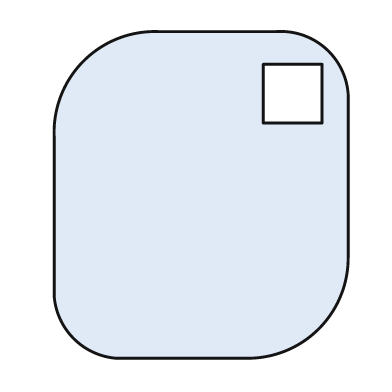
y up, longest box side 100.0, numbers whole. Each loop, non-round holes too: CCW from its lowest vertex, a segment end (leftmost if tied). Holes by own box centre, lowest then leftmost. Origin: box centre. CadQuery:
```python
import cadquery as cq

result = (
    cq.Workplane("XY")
    .moveTo(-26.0, -50.0)
    .lineTo(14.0, -50.0)
    .threePointArc((36.0, -41.0), (45.0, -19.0))
    .lineTo(45.0, 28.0)
    .threePointArc((39.0, 44.0), (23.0, 50.0))
    .lineTo(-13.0, 50.0)
    .threePointArc((-36.0, 41.0), (-45.0, 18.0))
    .lineTo(-45.0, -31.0)
    .threePointArc((-39.0, -44.0), (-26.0, -50.0))
    .close()
    .moveTo(19.0, 22.0)
    .lineTo(37.0, 22.0)
    .lineTo(37.0, 40.0)
    .lineTo(19.0, 40.0)
    .close()
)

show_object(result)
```